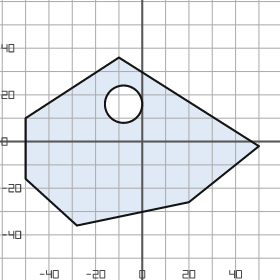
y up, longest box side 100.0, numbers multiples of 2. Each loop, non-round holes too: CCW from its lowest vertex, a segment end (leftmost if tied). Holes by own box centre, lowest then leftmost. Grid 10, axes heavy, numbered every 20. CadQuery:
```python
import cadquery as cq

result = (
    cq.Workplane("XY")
    .moveTo(-28.0, -36.0)
    .lineTo(20.0, -26.0)
    .lineTo(50.0, -2.0)
    .lineTo(-10.0, 36.0)
    .lineTo(-50.0, 10.0)
    .lineTo(-50.0, -16.0)
    .close()
    .moveTo(-8.0, 16.0)
    .circle(8.0)
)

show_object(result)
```